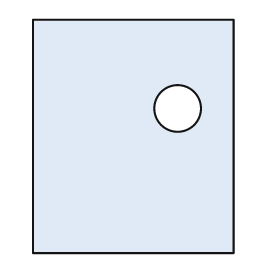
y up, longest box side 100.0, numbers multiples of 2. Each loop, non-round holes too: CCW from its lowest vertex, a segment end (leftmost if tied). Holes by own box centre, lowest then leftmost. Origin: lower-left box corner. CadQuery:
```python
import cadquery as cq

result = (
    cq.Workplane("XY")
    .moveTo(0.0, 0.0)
    .lineTo(86.0, 0.0)
    .lineTo(86.0, 100.0)
    .lineTo(0.0, 100.0)
    .close()
    .moveTo(62.0, 62.0)
    .circle(10.0)
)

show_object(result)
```